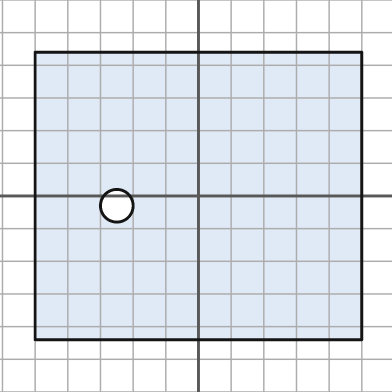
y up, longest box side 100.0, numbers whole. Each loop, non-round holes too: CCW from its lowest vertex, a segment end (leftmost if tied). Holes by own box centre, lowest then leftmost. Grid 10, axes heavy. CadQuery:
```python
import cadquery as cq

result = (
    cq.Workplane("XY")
    .moveTo(-50.0, -44.0)
    .lineTo(50.0, -44.0)
    .lineTo(50.0, 44.0)
    .lineTo(-50.0, 44.0)
    .close()
    .moveTo(-25.0, -3.0)
    .circle(5.0)
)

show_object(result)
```